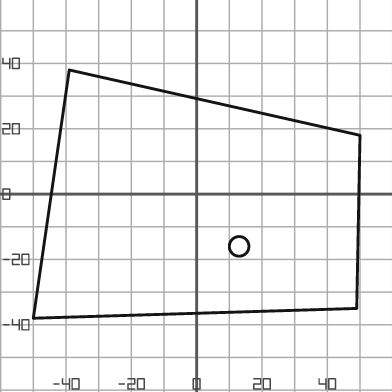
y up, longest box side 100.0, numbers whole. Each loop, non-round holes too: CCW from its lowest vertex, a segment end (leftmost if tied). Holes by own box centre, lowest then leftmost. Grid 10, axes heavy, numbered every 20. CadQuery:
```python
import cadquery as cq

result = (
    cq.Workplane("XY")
    .moveTo(-50.0, -38.0)
    .lineTo(49.0, -35.0)
    .lineTo(50.0, 18.0)
    .lineTo(-39.0, 38.0)
    .close()
    .moveTo(13.0, -16.0)
    .circle(3.0)
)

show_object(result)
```